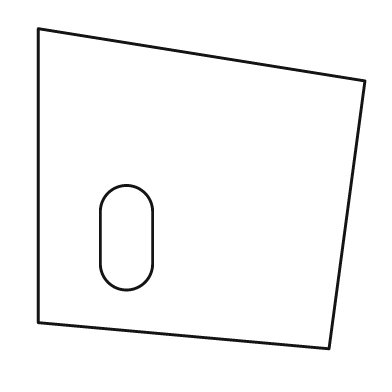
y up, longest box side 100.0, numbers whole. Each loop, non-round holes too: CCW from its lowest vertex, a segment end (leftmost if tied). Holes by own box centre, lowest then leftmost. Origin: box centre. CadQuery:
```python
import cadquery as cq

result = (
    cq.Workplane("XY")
    .moveTo(39.0, -49.0)
    .lineTo(50.0, 33.0)
    .lineTo(-50.0, 49.0)
    .lineTo(-50.0, -41.0)
    .close()
    .moveTo(-31.0, -23.0)
    .threePointArc((-23.0, -31.0), (-15.0, -23.0))
    .lineTo(-15.0, -7.0)
    .threePointArc((-23.0, 1.0), (-31.0, -7.0))
    .close()
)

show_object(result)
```